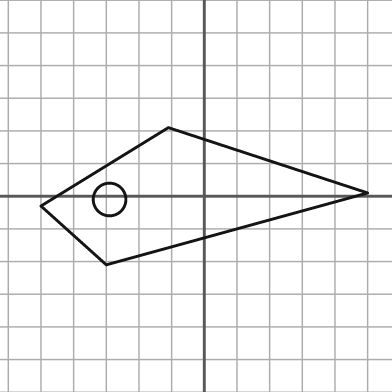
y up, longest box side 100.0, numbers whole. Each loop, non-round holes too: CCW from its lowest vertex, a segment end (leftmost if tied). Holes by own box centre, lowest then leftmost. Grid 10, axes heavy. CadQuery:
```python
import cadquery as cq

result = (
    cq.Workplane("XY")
    .moveTo(-30.0, -21.0)
    .lineTo(50.0, 1.0)
    .lineTo(-11.0, 21.0)
    .lineTo(-50.0, -3.0)
    .close()
    .moveTo(-29.0, -1.0)
    .circle(5.0)
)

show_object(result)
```